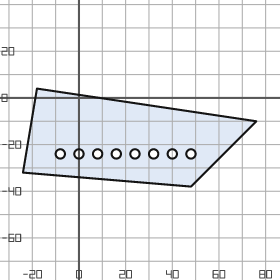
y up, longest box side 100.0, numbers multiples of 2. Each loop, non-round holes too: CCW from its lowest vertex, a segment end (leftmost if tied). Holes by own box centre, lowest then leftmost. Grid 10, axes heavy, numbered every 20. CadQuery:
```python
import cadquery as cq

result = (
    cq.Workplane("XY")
    .moveTo(48.0, -38.0)
    .lineTo(76.0, -10.0)
    .lineTo(-18.0, 4.0)
    .lineTo(-24.0, -32.0)
    .close()
    .moveTo(-8.0, -24.0)
    .circle(2.0)
    .moveTo(0.0, -24.0)
    .circle(2.0)
    .moveTo(8.0, -24.0)
    .circle(2.0)
    .moveTo(16.0, -24.0)
    .circle(2.0)
    .moveTo(24.0, -24.0)
    .circle(2.0)
    .moveTo(32.0, -24.0)
    .circle(2.0)
    .moveTo(40.0, -24.0)
    .circle(2.0)
    .moveTo(48.0, -24.0)
    .circle(2.0)
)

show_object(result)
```